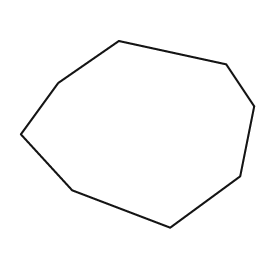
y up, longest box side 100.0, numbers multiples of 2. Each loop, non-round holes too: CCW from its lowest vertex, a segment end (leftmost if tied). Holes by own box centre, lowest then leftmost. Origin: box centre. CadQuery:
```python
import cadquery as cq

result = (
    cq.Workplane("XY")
    .moveTo(14.0, -40.0)
    .lineTo(44.0, -18.0)
    .lineTo(50.0, 12.0)
    .lineTo(38.0, 30.0)
    .lineTo(-8.0, 40.0)
    .lineTo(-34.0, 22.0)
    .lineTo(-50.0, 0.0)
    .lineTo(-28.0, -24.0)
    .close()
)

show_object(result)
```